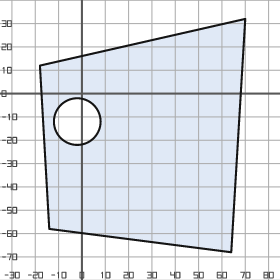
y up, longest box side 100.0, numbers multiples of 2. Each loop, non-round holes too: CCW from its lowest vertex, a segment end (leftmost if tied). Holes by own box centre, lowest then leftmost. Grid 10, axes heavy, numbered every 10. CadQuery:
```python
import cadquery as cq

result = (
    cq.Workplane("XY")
    .moveTo(64.0, -68.0)
    .lineTo(70.0, 32.0)
    .lineTo(-18.0, 12.0)
    .lineTo(-14.0, -58.0)
    .close()
    .moveTo(-2.0, -12.0)
    .circle(10.0)
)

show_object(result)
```